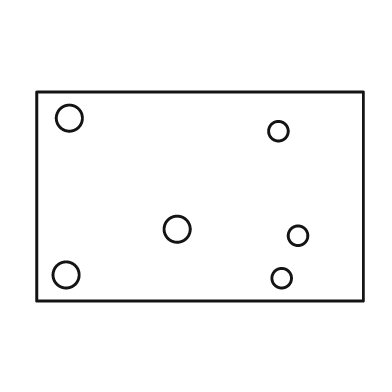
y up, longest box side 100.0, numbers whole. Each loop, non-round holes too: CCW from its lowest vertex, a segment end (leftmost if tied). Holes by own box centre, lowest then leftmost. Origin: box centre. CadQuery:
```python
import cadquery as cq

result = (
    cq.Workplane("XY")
    .moveTo(-50.0, -32.0)
    .lineTo(50.0, -32.0)
    .lineTo(50.0, 32.0)
    .lineTo(-50.0, 32.0)
    .close()
    .moveTo(25.0, -25.0)
    .circle(3.0)
    .moveTo(-41.0, -24.0)
    .circle(4.0)
    .moveTo(30.0, -12.0)
    .circle(3.0)
    .moveTo(-7.0, -10.0)
    .circle(4.0)
    .moveTo(24.0, 20.0)
    .circle(3.0)
    .moveTo(-40.0, 24.0)
    .circle(4.0)
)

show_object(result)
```